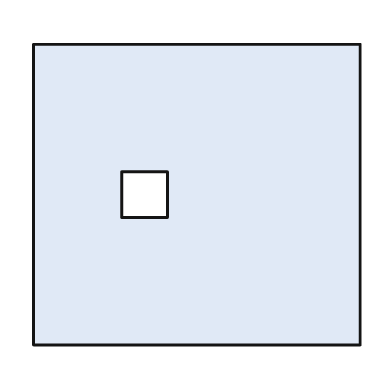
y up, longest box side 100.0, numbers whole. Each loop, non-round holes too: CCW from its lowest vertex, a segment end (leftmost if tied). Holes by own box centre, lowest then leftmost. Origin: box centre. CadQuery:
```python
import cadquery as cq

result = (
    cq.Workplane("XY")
    .moveTo(-50.0, -46.0)
    .lineTo(50.0, -46.0)
    .lineTo(50.0, 46.0)
    .lineTo(-50.0, 46.0)
    .close()
    .moveTo(-23.0, -7.0)
    .lineTo(-9.0, -7.0)
    .lineTo(-9.0, 7.0)
    .lineTo(-23.0, 7.0)
    .close()
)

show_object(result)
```